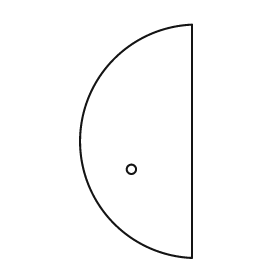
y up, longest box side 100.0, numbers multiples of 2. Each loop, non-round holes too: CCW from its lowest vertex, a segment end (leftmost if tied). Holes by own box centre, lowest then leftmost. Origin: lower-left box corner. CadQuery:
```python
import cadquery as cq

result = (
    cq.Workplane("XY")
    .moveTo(48.0, 0.0)
    .lineTo(48.0, 100.0)
    .threePointArc((0.0, 50.0), (48.0, 0.0))
    .close()
    .moveTo(22.0, 38.0)
    .circle(2.0)
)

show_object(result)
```